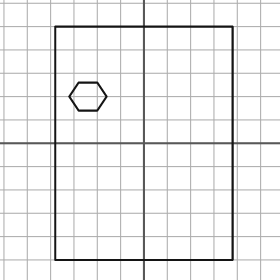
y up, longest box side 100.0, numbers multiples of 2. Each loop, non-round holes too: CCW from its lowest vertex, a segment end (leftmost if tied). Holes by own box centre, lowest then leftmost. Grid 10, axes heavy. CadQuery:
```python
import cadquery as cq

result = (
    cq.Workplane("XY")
    .moveTo(-38.0, -50.0)
    .lineTo(38.0, -50.0)
    .lineTo(38.0, 50.0)
    .lineTo(-38.0, 50.0)
    .close()
    .moveTo(-28.0, 14.0)
    .lineTo(-20.0, 14.0)
    .lineTo(-16.0, 20.0)
    .lineTo(-20.0, 26.0)
    .lineTo(-28.0, 26.0)
    .lineTo(-32.0, 20.0)
    .close()
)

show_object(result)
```